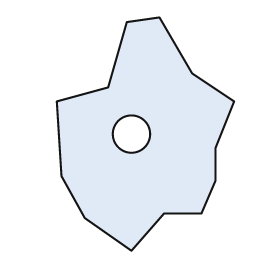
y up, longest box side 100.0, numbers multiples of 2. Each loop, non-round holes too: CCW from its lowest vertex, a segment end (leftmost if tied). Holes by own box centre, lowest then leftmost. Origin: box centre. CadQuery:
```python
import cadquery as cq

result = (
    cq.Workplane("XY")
    .moveTo(-6.0, -50.0)
    .lineTo(8.0, -34.0)
    .lineTo(24.0, -34.0)
    .lineTo(30.0, -20.0)
    .lineTo(30.0, -6.0)
    .lineTo(38.0, 14.0)
    .lineTo(20.0, 26.0)
    .lineTo(6.0, 50.0)
    .lineTo(-8.0, 48.0)
    .lineTo(-16.0, 20.0)
    .lineTo(-38.0, 14.0)
    .lineTo(-36.0, -18.0)
    .lineTo(-26.0, -36.0)
    .close()
    .moveTo(-6.0, 0.0)
    .circle(8.0)
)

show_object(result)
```